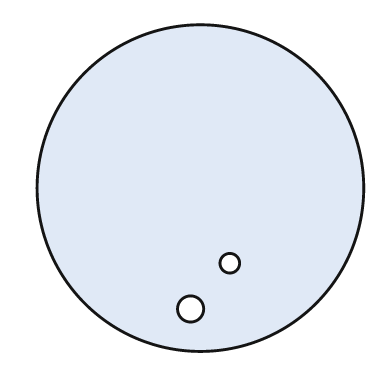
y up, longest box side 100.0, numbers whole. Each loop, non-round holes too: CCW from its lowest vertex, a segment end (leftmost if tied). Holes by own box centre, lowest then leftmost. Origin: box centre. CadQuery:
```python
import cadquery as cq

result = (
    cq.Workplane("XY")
    .moveTo(0.0, 0.0)
    .circle(50.0)
    .moveTo(-3.0, -37.0)
    .circle(4.0)
    .moveTo(9.0, -23.0)
    .circle(3.0)
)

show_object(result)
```